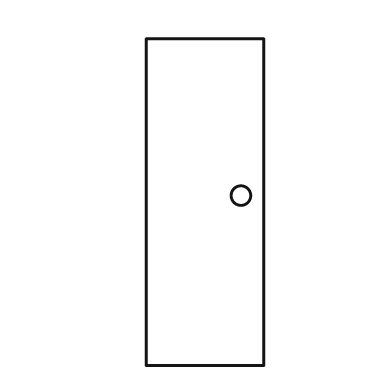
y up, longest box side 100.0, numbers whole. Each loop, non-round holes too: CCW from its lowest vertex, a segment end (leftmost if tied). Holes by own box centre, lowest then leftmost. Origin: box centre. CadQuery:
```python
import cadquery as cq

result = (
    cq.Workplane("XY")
    .moveTo(-18.0, -50.0)
    .lineTo(18.0, -50.0)
    .lineTo(18.0, 50.0)
    .lineTo(-18.0, 50.0)
    .close()
    .moveTo(11.0, 2.0)
    .circle(3.0)
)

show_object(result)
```